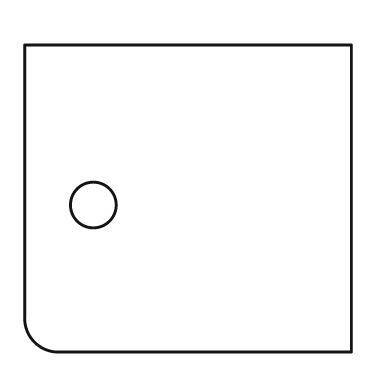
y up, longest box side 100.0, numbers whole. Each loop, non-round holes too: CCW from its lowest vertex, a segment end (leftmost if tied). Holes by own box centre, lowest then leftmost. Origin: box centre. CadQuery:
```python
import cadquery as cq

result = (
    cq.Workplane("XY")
    .moveTo(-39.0, -47.0)
    .lineTo(50.0, -47.0)
    .lineTo(50.0, 47.0)
    .lineTo(-50.0, 47.0)
    .lineTo(-50.0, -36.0)
    .threePointArc((-47.0, -44.0), (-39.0, -47.0))
    .close()
    .moveTo(-29.0, -2.0)
    .circle(7.0)
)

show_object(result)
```